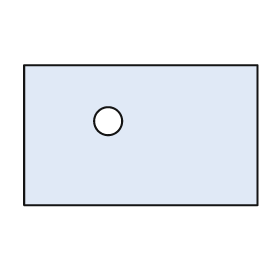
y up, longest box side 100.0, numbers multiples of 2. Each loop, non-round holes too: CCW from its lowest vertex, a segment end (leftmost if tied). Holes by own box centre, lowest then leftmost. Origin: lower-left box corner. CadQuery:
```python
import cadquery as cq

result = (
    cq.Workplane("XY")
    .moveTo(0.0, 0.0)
    .lineTo(100.0, 0.0)
    .lineTo(100.0, 60.0)
    .lineTo(0.0, 60.0)
    .close()
    .moveTo(36.0, 36.0)
    .circle(6.0)
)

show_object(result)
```